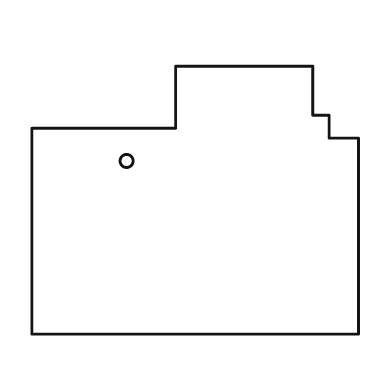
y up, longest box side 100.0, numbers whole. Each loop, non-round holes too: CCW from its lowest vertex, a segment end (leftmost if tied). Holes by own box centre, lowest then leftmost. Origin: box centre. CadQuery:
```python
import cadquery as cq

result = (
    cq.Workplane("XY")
    .moveTo(-50.0, -41.0)
    .lineTo(50.0, -41.0)
    .lineTo(50.0, 19.0)
    .lineTo(41.0, 19.0)
    .lineTo(41.0, 26.0)
    .lineTo(36.0, 26.0)
    .lineTo(36.0, 41.0)
    .lineTo(-6.0, 41.0)
    .lineTo(-6.0, 22.0)
    .lineTo(-50.0, 22.0)
    .close()
    .moveTo(-21.0, 12.0)
    .circle(2.0)
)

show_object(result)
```